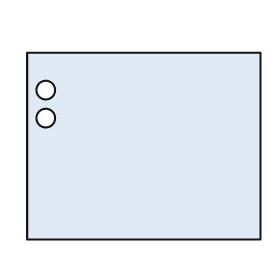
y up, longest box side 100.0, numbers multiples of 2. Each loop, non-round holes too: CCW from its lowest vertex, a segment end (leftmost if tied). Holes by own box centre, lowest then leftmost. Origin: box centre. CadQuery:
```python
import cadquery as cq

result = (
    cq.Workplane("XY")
    .moveTo(-50.0, -40.0)
    .lineTo(50.0, -40.0)
    .lineTo(50.0, 40.0)
    .lineTo(-50.0, 40.0)
    .close()
    .moveTo(-42.0, 12.0)
    .circle(4.0)
    .moveTo(-42.0, 24.0)
    .circle(4.0)
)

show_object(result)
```